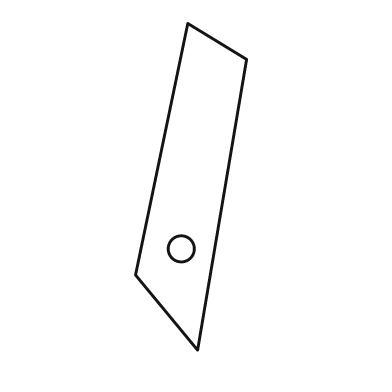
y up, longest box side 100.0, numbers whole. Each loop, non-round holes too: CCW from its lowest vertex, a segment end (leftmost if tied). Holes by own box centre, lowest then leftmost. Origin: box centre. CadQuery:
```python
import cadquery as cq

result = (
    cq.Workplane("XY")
    .moveTo(2.0, -50.0)
    .lineTo(17.0, 39.0)
    .lineTo(-1.0, 50.0)
    .lineTo(-17.0, -27.0)
    .close()
    .moveTo(-3.0, -19.0)
    .circle(4.0)
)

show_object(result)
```